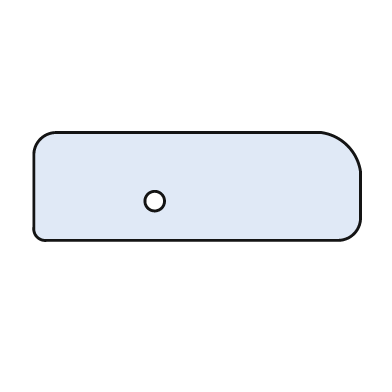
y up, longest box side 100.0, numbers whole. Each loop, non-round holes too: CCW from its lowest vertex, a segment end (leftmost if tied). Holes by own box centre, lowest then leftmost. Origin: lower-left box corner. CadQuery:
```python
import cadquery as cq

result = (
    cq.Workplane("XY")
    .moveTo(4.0, 0.0)
    .lineTo(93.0, 0.0)
    .threePointArc((98.0, 2.0), (100.0, 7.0))
    .lineTo(100.0, 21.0)
    .threePointArc((96.0, 29.0), (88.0, 33.0))
    .lineTo(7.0, 33.0)
    .threePointArc((2.0, 31.0), (0.0, 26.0))
    .lineTo(0.0, 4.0)
    .threePointArc((1.0, 1.0), (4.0, 0.0))
    .close()
    .moveTo(37.0, 12.0)
    .circle(3.0)
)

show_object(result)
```